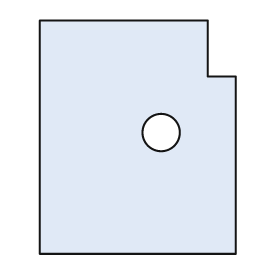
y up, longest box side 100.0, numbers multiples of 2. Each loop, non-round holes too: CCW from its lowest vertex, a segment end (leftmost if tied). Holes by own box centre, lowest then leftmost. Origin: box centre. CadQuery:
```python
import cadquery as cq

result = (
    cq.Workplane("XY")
    .moveTo(-42.0, -50.0)
    .lineTo(42.0, -50.0)
    .lineTo(42.0, 26.0)
    .lineTo(30.0, 26.0)
    .lineTo(30.0, 50.0)
    .lineTo(-42.0, 50.0)
    .close()
    .moveTo(10.0, 2.0)
    .circle(8.0)
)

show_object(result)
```